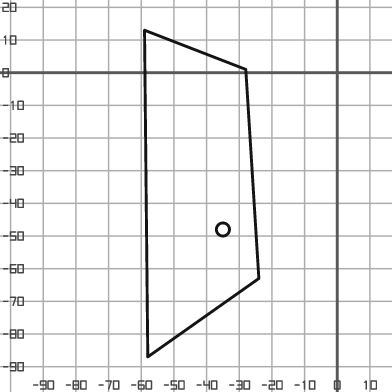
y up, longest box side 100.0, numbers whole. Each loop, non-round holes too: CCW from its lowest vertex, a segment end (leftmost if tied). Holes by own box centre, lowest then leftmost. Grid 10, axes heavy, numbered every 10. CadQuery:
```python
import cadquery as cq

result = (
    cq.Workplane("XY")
    .moveTo(-58.0, -87.0)
    .lineTo(-24.0, -63.0)
    .lineTo(-28.0, 1.0)
    .lineTo(-59.0, 13.0)
    .close()
    .moveTo(-35.0, -48.0)
    .circle(2.0)
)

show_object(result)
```